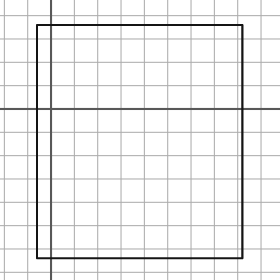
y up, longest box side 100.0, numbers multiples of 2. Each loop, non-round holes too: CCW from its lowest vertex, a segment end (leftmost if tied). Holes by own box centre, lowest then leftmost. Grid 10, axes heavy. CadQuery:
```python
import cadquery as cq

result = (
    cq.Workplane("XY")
    .moveTo(-6.0, -64.0)
    .lineTo(82.0, -64.0)
    .lineTo(82.0, 36.0)
    .lineTo(-6.0, 36.0)
    .close()
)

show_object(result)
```